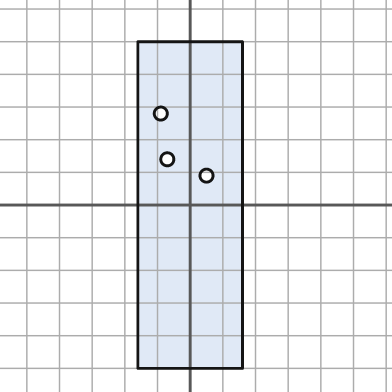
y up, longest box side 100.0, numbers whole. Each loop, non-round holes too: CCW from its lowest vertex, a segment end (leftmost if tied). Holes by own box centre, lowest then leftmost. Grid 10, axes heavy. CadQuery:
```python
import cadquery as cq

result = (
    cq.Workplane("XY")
    .moveTo(-16.0, -50.0)
    .lineTo(16.0, -50.0)
    .lineTo(16.0, 50.0)
    .lineTo(-16.0, 50.0)
    .close()
    .moveTo(5.0, 9.0)
    .circle(2.0)
    .moveTo(-7.0, 14.0)
    .circle(2.0)
    .moveTo(-9.0, 28.0)
    .circle(2.0)
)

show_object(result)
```